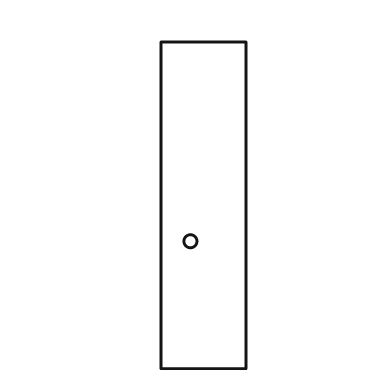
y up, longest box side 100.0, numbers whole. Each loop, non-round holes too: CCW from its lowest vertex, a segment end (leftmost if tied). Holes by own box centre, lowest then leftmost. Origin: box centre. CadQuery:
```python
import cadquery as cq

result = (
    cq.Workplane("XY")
    .moveTo(-13.0, -50.0)
    .lineTo(13.0, -50.0)
    .lineTo(13.0, 50.0)
    .lineTo(-13.0, 50.0)
    .close()
    .moveTo(-4.0, -11.0)
    .circle(2.0)
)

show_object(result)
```